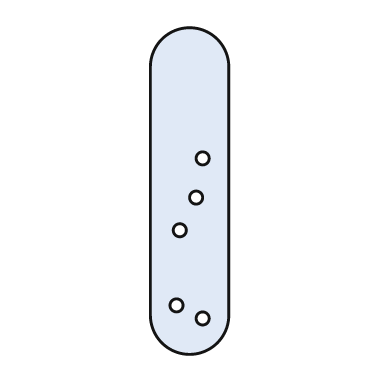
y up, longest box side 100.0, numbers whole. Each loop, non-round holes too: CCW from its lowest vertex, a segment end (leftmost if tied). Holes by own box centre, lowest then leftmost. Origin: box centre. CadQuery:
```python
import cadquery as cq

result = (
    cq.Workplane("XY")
    .moveTo(-12.0, -38.0)
    .threePointArc((0.0, -50.0), (12.0, -38.0))
    .lineTo(12.0, 38.0)
    .threePointArc((0.0, 50.0), (-12.0, 38.0))
    .close()
    .moveTo(4.0, -39.0)
    .circle(2.0)
    .moveTo(-4.0, -35.0)
    .circle(2.0)
    .moveTo(-3.0, -12.0)
    .circle(2.0)
    .moveTo(2.0, -2.0)
    .circle(2.0)
    .moveTo(4.0, 10.0)
    .circle(2.0)
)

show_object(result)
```